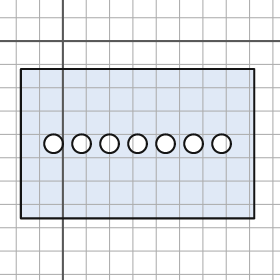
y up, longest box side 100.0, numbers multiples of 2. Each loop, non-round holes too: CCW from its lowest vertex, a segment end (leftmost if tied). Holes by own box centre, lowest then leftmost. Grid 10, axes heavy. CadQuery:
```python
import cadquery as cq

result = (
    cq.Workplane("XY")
    .moveTo(-18.0, -76.0)
    .lineTo(82.0, -76.0)
    .lineTo(82.0, -12.0)
    .lineTo(-18.0, -12.0)
    .close()
    .moveTo(-4.0, -44.0)
    .circle(4.0)
    .moveTo(8.0, -44.0)
    .circle(4.0)
    .moveTo(20.0, -44.0)
    .circle(4.0)
    .moveTo(32.0, -44.0)
    .circle(4.0)
    .moveTo(44.0, -44.0)
    .circle(4.0)
    .moveTo(56.0, -44.0)
    .circle(4.0)
    .moveTo(68.0, -44.0)
    .circle(4.0)
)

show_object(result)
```